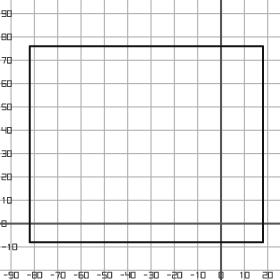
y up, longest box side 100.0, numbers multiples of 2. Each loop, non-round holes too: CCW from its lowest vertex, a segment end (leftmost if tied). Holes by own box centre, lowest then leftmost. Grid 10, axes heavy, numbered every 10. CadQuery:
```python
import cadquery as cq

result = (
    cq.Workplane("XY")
    .moveTo(-82.0, -8.0)
    .lineTo(18.0, -8.0)
    .lineTo(18.0, 76.0)
    .lineTo(-82.0, 76.0)
    .close()
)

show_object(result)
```